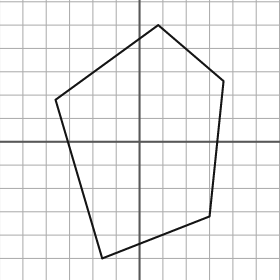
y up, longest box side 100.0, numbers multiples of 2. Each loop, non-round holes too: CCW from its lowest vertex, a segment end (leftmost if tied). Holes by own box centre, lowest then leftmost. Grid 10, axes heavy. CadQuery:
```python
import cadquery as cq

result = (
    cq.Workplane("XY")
    .moveTo(-16.0, -50.0)
    .lineTo(30.0, -32.0)
    .lineTo(36.0, 26.0)
    .lineTo(8.0, 50.0)
    .lineTo(-36.0, 18.0)
    .close()
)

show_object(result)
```